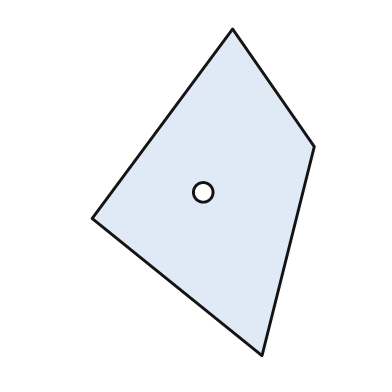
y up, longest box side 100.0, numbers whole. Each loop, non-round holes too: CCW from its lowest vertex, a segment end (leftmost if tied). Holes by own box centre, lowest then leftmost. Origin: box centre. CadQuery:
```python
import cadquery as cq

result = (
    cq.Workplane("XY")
    .moveTo(18.0, -50.0)
    .lineTo(34.0, 14.0)
    .lineTo(9.0, 50.0)
    .lineTo(-34.0, -8.0)
    .close()
    .moveTo(0.0, 0.0)
    .circle(3.0)
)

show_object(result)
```